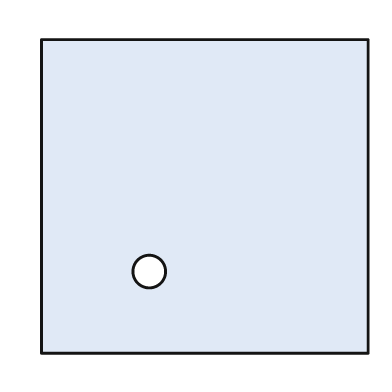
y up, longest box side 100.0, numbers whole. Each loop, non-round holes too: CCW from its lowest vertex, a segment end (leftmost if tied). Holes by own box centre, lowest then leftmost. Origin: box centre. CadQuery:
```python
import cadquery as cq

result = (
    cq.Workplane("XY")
    .moveTo(-50.0, -48.0)
    .lineTo(50.0, -48.0)
    .lineTo(50.0, 48.0)
    .lineTo(-50.0, 48.0)
    .close()
    .moveTo(-17.0, -23.0)
    .circle(5.0)
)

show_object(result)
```